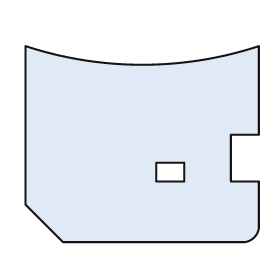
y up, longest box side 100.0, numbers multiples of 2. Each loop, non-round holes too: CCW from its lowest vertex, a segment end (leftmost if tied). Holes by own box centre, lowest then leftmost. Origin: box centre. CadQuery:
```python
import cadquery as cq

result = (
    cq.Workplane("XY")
    .moveTo(-34.0, -42.0)
    .lineTo(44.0, -42.0)
    .threePointArc((48.0, -40.0), (50.0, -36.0))
    .lineTo(50.0, -16.0)
    .lineTo(38.0, -16.0)
    .lineTo(38.0, 4.0)
    .lineTo(50.0, 4.0)
    .lineTo(50.0, 42.0)
    .threePointArc((0.0, 34.0), (-50.0, 42.0))
    .lineTo(-50.0, -26.0)
    .close()
    .moveTo(6.0, -16.0)
    .lineTo(18.0, -16.0)
    .lineTo(18.0, -8.0)
    .lineTo(6.0, -8.0)
    .close()
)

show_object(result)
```